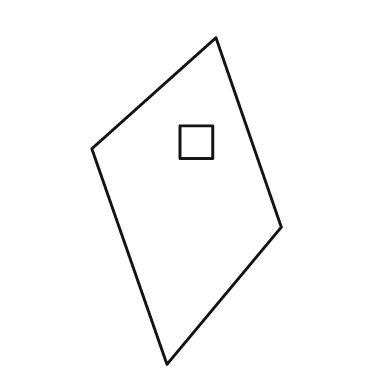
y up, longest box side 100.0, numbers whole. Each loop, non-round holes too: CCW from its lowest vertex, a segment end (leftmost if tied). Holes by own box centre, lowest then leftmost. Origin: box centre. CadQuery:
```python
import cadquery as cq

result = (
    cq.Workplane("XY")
    .moveTo(-6.0, -50.0)
    .lineTo(29.0, -8.0)
    .lineTo(9.0, 50.0)
    .lineTo(-29.0, 16.0)
    .close()
    .moveTo(-2.0, 13.0)
    .lineTo(8.0, 13.0)
    .lineTo(8.0, 23.0)
    .lineTo(-2.0, 23.0)
    .close()
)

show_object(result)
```